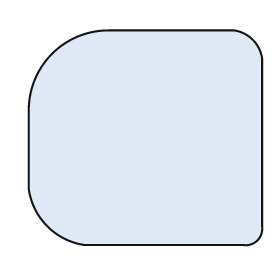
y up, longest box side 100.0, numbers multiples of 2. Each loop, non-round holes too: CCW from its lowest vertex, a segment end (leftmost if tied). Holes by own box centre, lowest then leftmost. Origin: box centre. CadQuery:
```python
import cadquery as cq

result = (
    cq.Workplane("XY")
    .moveTo(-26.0, -46.0)
    .lineTo(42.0, -46.0)
    .threePointArc((48.0, -44.0), (50.0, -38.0))
    .lineTo(50.0, 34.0)
    .threePointArc((46.0, 42.0), (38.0, 46.0))
    .lineTo(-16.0, 46.0)
    .threePointArc((-40.0, 36.0), (-50.0, 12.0))
    .lineTo(-50.0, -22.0)
    .threePointArc((-42.0, -38.0), (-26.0, -46.0))
    .close()
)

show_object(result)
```